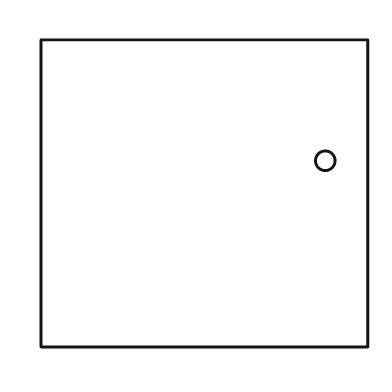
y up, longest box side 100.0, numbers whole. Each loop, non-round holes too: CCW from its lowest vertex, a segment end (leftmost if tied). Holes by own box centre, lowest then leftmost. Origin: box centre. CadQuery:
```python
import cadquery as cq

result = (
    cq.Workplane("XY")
    .moveTo(-50.0, -47.0)
    .lineTo(50.0, -47.0)
    .lineTo(50.0, 47.0)
    .lineTo(-50.0, 47.0)
    .close()
    .moveTo(37.0, 10.0)
    .circle(3.0)
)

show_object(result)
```